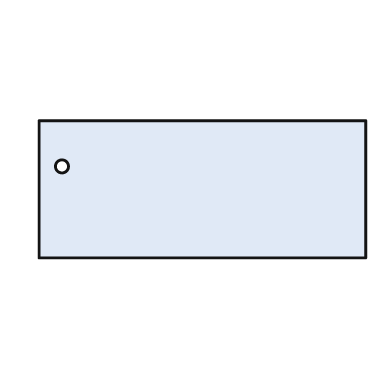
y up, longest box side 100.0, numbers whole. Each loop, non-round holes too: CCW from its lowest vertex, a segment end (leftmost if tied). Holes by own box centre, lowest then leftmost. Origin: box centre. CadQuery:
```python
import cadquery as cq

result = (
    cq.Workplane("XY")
    .moveTo(-50.0, -21.0)
    .lineTo(50.0, -21.0)
    .lineTo(50.0, 21.0)
    .lineTo(-50.0, 21.0)
    .close()
    .moveTo(-43.0, 7.0)
    .circle(2.0)
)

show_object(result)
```